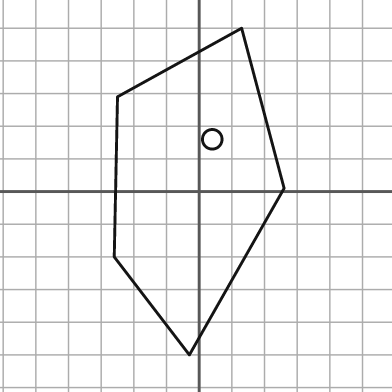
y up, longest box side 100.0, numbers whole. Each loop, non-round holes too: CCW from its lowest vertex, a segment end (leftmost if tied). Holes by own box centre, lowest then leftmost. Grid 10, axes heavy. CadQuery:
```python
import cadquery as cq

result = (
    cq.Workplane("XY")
    .moveTo(-3.0, -50.0)
    .lineTo(26.0, 1.0)
    .lineTo(13.0, 50.0)
    .lineTo(-25.0, 29.0)
    .lineTo(-26.0, -20.0)
    .close()
    .moveTo(4.0, 16.0)
    .circle(3.0)
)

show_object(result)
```